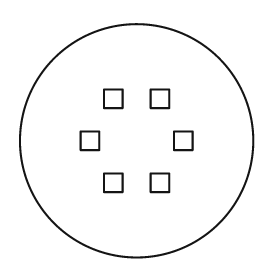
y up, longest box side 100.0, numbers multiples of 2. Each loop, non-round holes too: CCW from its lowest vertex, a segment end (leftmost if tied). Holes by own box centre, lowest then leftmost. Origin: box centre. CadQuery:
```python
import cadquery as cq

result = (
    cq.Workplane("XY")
    .moveTo(0.0, 0.0)
    .circle(50.0)
    .moveTo(-14.0, -22.0)
    .lineTo(-6.0, -22.0)
    .lineTo(-6.0, -14.0)
    .lineTo(-14.0, -14.0)
    .close()
    .moveTo(6.0, -22.0)
    .lineTo(14.0, -22.0)
    .lineTo(14.0, -14.0)
    .lineTo(6.0, -14.0)
    .close()
    .moveTo(-24.0, -4.0)
    .lineTo(-16.0, -4.0)
    .lineTo(-16.0, 4.0)
    .lineTo(-24.0, 4.0)
    .close()
    .moveTo(16.0, -4.0)
    .lineTo(24.0, -4.0)
    .lineTo(24.0, 4.0)
    .lineTo(16.0, 4.0)
    .close()
    .moveTo(-14.0, 14.0)
    .lineTo(-6.0, 14.0)
    .lineTo(-6.0, 22.0)
    .lineTo(-14.0, 22.0)
    .close()
    .moveTo(6.0, 14.0)
    .lineTo(14.0, 14.0)
    .lineTo(14.0, 22.0)
    .lineTo(6.0, 22.0)
    .close()
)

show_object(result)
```